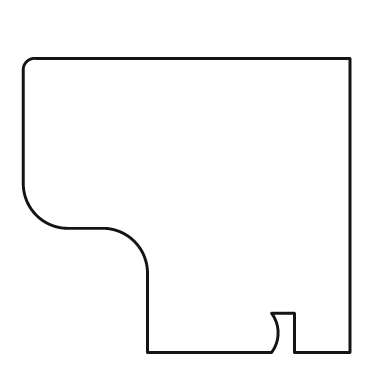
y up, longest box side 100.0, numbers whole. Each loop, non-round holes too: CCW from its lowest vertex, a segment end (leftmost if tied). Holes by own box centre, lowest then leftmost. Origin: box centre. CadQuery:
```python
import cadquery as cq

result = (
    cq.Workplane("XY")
    .moveTo(-12.0, -45.0)
    .lineTo(26.0, -45.0)
    .threePointArc((28.0, -39.0), (26.0, -33.0))
    .lineTo(33.0, -33.0)
    .lineTo(33.0, -45.0)
    .lineTo(50.0, -45.0)
    .lineTo(50.0, 45.0)
    .lineTo(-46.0, 45.0)
    .threePointArc((-49.0, 44.0), (-50.0, 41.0))
    .lineTo(-50.0, 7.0)
    .threePointArc((-46.0, -3.0), (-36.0, -7.0))
    .lineTo(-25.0, -7.0)
    .threePointArc((-16.0, -11.0), (-12.0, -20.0))
    .close()
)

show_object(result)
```